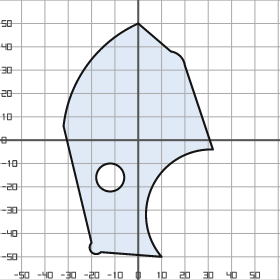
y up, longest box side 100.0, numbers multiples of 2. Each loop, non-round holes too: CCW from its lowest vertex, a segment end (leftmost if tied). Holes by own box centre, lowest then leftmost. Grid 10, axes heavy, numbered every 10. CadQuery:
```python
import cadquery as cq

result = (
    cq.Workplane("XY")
    .moveTo(10.0, -50.0)
    .threePointArc((6.0, -20.0), (32.0, -4.0))
    .lineTo(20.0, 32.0)
    .threePointArc((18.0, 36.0), (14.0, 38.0))
    .lineTo(0.0, 50.0)
    .threePointArc((-22.0, 32.0), (-32.0, 6.0))
    .lineTo(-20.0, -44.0)
    .threePointArc((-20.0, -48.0), (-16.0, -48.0))
    .close()
    .moveTo(-12.0, -16.0)
    .circle(6.0)
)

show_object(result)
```